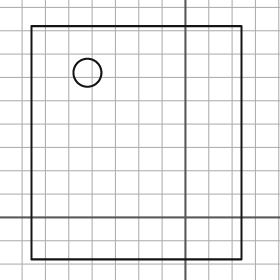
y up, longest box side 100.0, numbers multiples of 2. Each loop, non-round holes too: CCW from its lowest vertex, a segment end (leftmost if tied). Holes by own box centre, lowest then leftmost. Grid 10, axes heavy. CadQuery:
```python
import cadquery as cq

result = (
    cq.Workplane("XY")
    .moveTo(-66.0, -18.0)
    .lineTo(24.0, -18.0)
    .lineTo(24.0, 82.0)
    .lineTo(-66.0, 82.0)
    .close()
    .moveTo(-42.0, 62.0)
    .circle(6.0)
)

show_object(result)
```